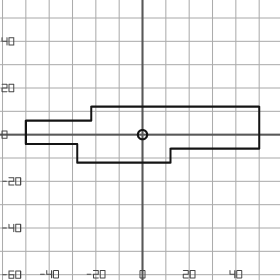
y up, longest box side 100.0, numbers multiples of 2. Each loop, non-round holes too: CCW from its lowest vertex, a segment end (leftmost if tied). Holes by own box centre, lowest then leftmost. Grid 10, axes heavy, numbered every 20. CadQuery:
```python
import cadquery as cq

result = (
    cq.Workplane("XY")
    .moveTo(-28.0, -12.0)
    .lineTo(12.0, -12.0)
    .lineTo(12.0, -6.0)
    .lineTo(50.0, -6.0)
    .lineTo(50.0, 12.0)
    .lineTo(-22.0, 12.0)
    .lineTo(-22.0, 6.0)
    .lineTo(-50.0, 6.0)
    .lineTo(-50.0, -4.0)
    .lineTo(-28.0, -4.0)
    .close()
    .moveTo(0.0, 0.0)
    .circle(2.0)
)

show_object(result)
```